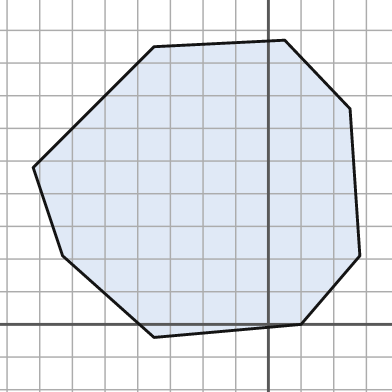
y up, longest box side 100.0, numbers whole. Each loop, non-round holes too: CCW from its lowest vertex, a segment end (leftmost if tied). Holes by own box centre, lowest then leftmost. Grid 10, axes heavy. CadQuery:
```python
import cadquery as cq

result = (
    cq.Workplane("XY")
    .moveTo(-35.0, -4.0)
    .lineTo(10.0, 0.0)
    .lineTo(28.0, 21.0)
    .lineTo(25.0, 66.0)
    .lineTo(5.0, 87.0)
    .lineTo(-35.0, 85.0)
    .lineTo(-72.0, 48.0)
    .lineTo(-63.0, 21.0)
    .close()
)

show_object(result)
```